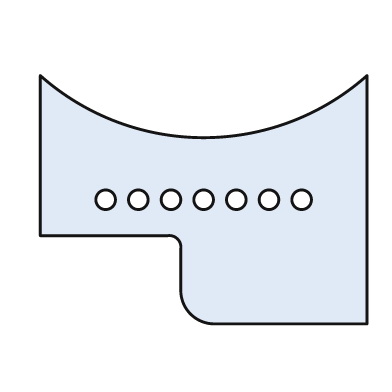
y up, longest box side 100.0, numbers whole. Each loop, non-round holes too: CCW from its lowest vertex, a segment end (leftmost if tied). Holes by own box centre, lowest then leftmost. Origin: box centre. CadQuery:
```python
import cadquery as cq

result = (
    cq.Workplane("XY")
    .moveTo(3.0, -38.0)
    .lineTo(50.0, -38.0)
    .lineTo(50.0, 38.0)
    .threePointArc((0.0, 19.0), (-50.0, 38.0))
    .lineTo(-50.0, -11.0)
    .lineTo(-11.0, -11.0)
    .threePointArc((-8.0, -12.0), (-7.0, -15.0))
    .lineTo(-7.0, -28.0)
    .threePointArc((-4.0, -35.0), (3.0, -38.0))
    .close()
    .moveTo(-30.0, 0.0)
    .circle(3.0)
    .moveTo(-20.0, 0.0)
    .circle(3.0)
    .moveTo(-10.0, 0.0)
    .circle(3.0)
    .moveTo(0.0, 0.0)
    .circle(3.0)
    .moveTo(10.0, 0.0)
    .circle(3.0)
    .moveTo(20.0, 0.0)
    .circle(3.0)
    .moveTo(30.0, 0.0)
    .circle(3.0)
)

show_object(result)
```